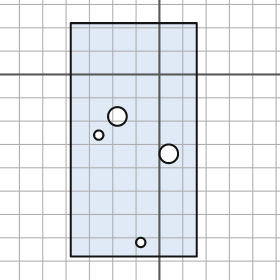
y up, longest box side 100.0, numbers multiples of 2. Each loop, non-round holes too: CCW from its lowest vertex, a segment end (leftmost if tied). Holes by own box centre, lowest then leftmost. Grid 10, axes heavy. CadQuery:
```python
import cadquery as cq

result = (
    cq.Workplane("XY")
    .moveTo(-38.0, -78.0)
    .lineTo(16.0, -78.0)
    .lineTo(16.0, 22.0)
    .lineTo(-38.0, 22.0)
    .close()
    .moveTo(-8.0, -72.0)
    .circle(2.0)
    .moveTo(4.0, -34.0)
    .circle(4.0)
    .moveTo(-26.0, -26.0)
    .circle(2.0)
    .moveTo(-18.0, -18.0)
    .circle(4.0)
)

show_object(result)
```